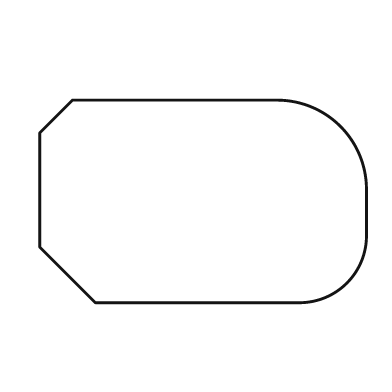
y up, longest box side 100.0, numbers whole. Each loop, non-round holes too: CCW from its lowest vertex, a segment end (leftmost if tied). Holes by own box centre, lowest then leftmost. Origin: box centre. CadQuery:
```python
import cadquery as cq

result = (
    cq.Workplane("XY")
    .moveTo(-33.0, -31.0)
    .lineTo(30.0, -31.0)
    .threePointArc((44.0, -25.0), (50.0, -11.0))
    .lineTo(50.0, 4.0)
    .threePointArc((42.0, 23.0), (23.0, 31.0))
    .lineTo(-40.0, 31.0)
    .lineTo(-50.0, 21.0)
    .lineTo(-50.0, -14.0)
    .close()
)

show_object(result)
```